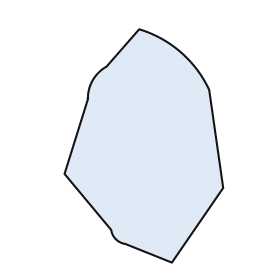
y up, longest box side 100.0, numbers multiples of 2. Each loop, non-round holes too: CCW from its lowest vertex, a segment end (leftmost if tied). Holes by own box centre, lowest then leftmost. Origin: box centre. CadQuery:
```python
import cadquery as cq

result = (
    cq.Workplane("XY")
    .moveTo(12.0, -50.0)
    .lineTo(34.0, -18.0)
    .lineTo(28.0, 24.0)
    .threePointArc((16.0, 40.0), (-2.0, 50.0))
    .lineTo(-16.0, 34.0)
    .threePointArc((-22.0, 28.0), (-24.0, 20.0))
    .lineTo(-34.0, -12.0)
    .lineTo(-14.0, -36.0)
    .threePointArc((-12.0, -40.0), (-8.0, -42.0))
    .close()
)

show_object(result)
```